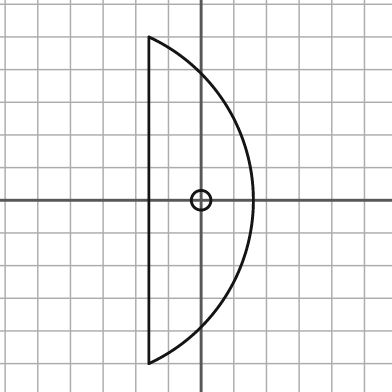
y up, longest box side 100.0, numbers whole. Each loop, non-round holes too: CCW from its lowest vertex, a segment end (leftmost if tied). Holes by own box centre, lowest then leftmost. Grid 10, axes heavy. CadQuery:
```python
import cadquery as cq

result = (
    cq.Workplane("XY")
    .moveTo(-16.0, -50.0)
    .threePointArc((16.0, 0.0), (-16.0, 50.0))
    .close()
    .moveTo(0.0, 0.0)
    .circle(3.0)
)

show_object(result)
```